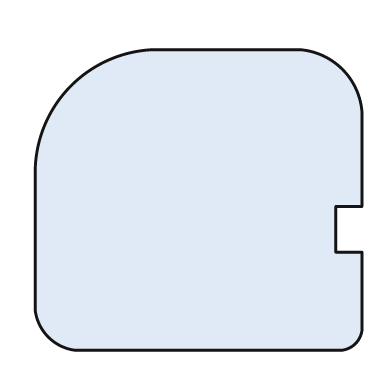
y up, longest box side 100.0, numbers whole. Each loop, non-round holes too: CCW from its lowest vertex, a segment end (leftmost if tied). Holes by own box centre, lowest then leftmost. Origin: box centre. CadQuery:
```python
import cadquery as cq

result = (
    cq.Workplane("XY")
    .moveTo(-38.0, -46.0)
    .lineTo(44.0, -46.0)
    .threePointArc((48.0, -44.0), (50.0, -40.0))
    .lineTo(50.0, -16.0)
    .lineTo(42.0, -16.0)
    .lineTo(42.0, -2.0)
    .lineTo(50.0, -2.0)
    .lineTo(50.0, 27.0)
    .threePointArc((44.0, 40.0), (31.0, 46.0))
    .lineTo(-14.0, 46.0)
    .threePointArc((-39.0, 35.0), (-50.0, 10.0))
    .lineTo(-50.0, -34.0)
    .threePointArc((-46.0, -42.0), (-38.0, -46.0))
    .close()
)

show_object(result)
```